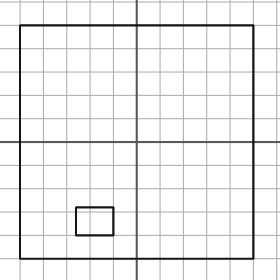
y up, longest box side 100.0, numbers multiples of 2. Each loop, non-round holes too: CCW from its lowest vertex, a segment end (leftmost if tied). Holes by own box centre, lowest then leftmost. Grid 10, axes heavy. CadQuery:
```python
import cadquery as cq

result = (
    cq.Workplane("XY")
    .moveTo(-50.0, -50.0)
    .lineTo(50.0, -50.0)
    .lineTo(50.0, 50.0)
    .lineTo(-50.0, 50.0)
    .close()
    .moveTo(-26.0, -40.0)
    .lineTo(-10.0, -40.0)
    .lineTo(-10.0, -28.0)
    .lineTo(-26.0, -28.0)
    .close()
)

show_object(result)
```